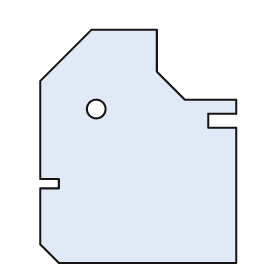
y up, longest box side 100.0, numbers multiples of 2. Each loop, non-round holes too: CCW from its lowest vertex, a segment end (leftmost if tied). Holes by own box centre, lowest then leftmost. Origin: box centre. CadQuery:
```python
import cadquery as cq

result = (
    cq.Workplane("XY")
    .moveTo(-34.0, -50.0)
    .lineTo(42.0, -50.0)
    .lineTo(42.0, 8.0)
    .lineTo(30.0, 8.0)
    .lineTo(30.0, 14.0)
    .lineTo(42.0, 14.0)
    .lineTo(42.0, 20.0)
    .lineTo(20.0, 20.0)
    .lineTo(8.0, 32.0)
    .lineTo(8.0, 50.0)
    .lineTo(-20.0, 50.0)
    .lineTo(-42.0, 28.0)
    .lineTo(-42.0, -14.0)
    .lineTo(-34.0, -14.0)
    .lineTo(-34.0, -18.0)
    .lineTo(-42.0, -18.0)
    .lineTo(-42.0, -42.0)
    .close()
    .moveTo(-18.0, 16.0)
    .circle(4.0)
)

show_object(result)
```